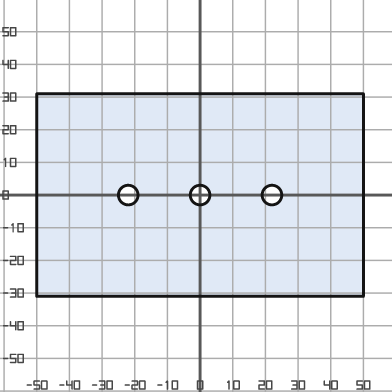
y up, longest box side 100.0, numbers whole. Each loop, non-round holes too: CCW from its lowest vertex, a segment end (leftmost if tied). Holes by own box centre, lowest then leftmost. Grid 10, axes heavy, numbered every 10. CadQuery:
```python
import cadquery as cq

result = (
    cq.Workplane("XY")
    .moveTo(-50.0, -31.0)
    .lineTo(50.0, -31.0)
    .lineTo(50.0, 31.0)
    .lineTo(-50.0, 31.0)
    .close()
    .moveTo(-22.0, 0.0)
    .circle(3.0)
    .moveTo(0.0, 0.0)
    .circle(3.0)
    .moveTo(22.0, 0.0)
    .circle(3.0)
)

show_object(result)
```